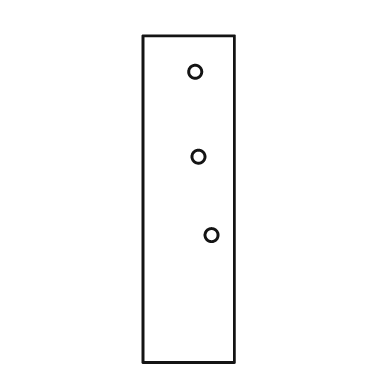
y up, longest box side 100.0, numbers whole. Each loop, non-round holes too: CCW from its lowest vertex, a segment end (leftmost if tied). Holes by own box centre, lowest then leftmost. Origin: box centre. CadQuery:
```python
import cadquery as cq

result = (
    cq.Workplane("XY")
    .moveTo(-14.0, -50.0)
    .lineTo(14.0, -50.0)
    .lineTo(14.0, 50.0)
    .lineTo(-14.0, 50.0)
    .close()
    .moveTo(7.0, -11.0)
    .circle(2.0)
    .moveTo(3.0, 13.0)
    .circle(2.0)
    .moveTo(2.0, 39.0)
    .circle(2.0)
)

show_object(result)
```